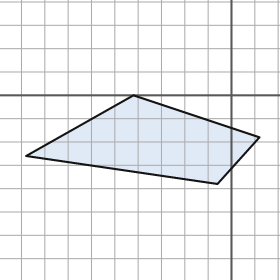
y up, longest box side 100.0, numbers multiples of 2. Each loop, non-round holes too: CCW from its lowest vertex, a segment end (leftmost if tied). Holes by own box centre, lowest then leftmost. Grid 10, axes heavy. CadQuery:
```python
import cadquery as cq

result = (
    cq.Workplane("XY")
    .moveTo(-6.0, -38.0)
    .lineTo(12.0, -18.0)
    .lineTo(-42.0, 0.0)
    .lineTo(-88.0, -26.0)
    .close()
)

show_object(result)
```